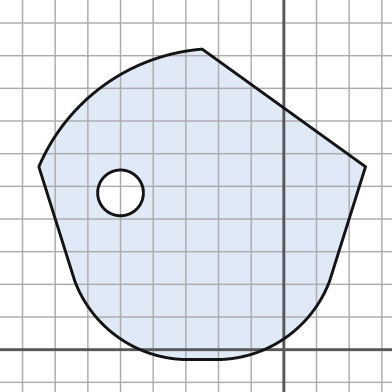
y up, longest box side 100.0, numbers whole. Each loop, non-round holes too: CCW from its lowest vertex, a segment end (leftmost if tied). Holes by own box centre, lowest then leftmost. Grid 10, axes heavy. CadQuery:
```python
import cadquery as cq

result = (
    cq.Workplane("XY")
    .moveTo(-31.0, -3.0)
    .lineTo(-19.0, -3.0)
    .threePointArc((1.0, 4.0), (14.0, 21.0))
    .lineTo(25.0, 56.0)
    .lineTo(-25.0, 92.0)
    .threePointArc((-55.0, 81.0), (-75.0, 56.0))
    .lineTo(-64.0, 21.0)
    .threePointArc((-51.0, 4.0), (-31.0, -3.0))
    .close()
    .moveTo(-50.0, 48.0)
    .circle(7.0)
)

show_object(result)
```